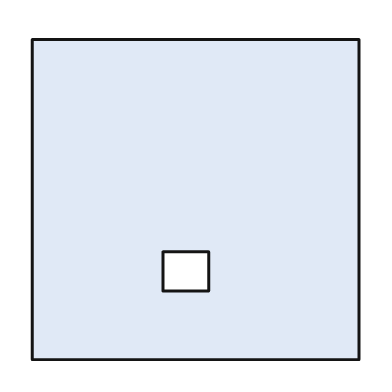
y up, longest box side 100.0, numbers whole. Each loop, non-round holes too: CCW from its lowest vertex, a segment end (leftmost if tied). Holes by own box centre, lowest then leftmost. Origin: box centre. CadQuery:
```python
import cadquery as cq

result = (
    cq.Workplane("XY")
    .moveTo(-50.0, -49.0)
    .lineTo(50.0, -49.0)
    .lineTo(50.0, 49.0)
    .lineTo(-50.0, 49.0)
    .close()
    .moveTo(-10.0, -28.0)
    .lineTo(4.0, -28.0)
    .lineTo(4.0, -16.0)
    .lineTo(-10.0, -16.0)
    .close()
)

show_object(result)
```